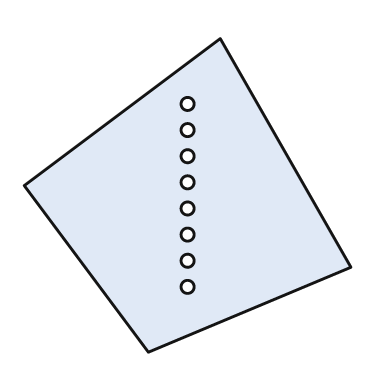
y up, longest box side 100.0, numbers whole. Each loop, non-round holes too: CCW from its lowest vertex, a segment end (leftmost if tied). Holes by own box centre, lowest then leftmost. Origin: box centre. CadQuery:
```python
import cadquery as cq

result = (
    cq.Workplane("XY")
    .moveTo(-12.0, -48.0)
    .lineTo(50.0, -22.0)
    .lineTo(10.0, 48.0)
    .lineTo(-50.0, 3.0)
    .close()
    .moveTo(0.0, -28.0)
    .circle(2.0)
    .moveTo(0.0, -20.0)
    .circle(2.0)
    .moveTo(0.0, -12.0)
    .circle(2.0)
    .moveTo(0.0, -4.0)
    .circle(2.0)
    .moveTo(0.0, 4.0)
    .circle(2.0)
    .moveTo(0.0, 12.0)
    .circle(2.0)
    .moveTo(0.0, 20.0)
    .circle(2.0)
    .moveTo(0.0, 28.0)
    .circle(2.0)
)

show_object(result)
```